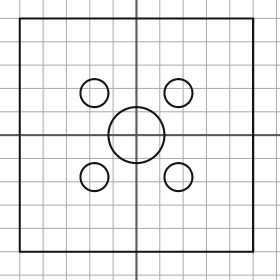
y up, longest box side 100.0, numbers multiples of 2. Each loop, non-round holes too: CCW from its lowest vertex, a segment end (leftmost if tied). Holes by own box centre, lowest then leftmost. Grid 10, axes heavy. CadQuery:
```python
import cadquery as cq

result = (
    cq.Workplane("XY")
    .moveTo(-50.0, -50.0)
    .lineTo(50.0, -50.0)
    .lineTo(50.0, 50.0)
    .lineTo(-50.0, 50.0)
    .close()
    .moveTo(-18.0, -18.0)
    .circle(6.0)
    .moveTo(18.0, -18.0)
    .circle(6.0)
    .moveTo(0.0, 0.0)
    .circle(12.0)
    .moveTo(-18.0, 18.0)
    .circle(6.0)
    .moveTo(18.0, 18.0)
    .circle(6.0)
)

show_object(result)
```